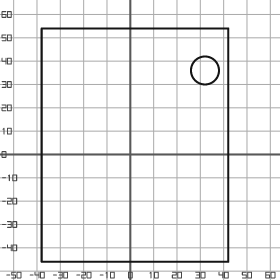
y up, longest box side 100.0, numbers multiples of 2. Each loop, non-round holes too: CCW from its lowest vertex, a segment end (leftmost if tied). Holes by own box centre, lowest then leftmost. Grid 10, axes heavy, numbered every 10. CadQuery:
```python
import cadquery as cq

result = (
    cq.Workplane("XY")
    .moveTo(-38.0, -46.0)
    .lineTo(42.0, -46.0)
    .lineTo(42.0, 54.0)
    .lineTo(-38.0, 54.0)
    .close()
    .moveTo(32.0, 36.0)
    .circle(6.0)
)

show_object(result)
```